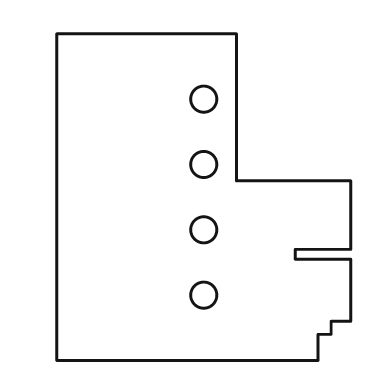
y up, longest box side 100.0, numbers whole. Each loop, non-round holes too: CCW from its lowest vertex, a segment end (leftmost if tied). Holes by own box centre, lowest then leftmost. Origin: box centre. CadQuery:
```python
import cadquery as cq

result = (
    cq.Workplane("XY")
    .moveTo(-45.0, -50.0)
    .lineTo(35.0, -50.0)
    .lineTo(35.0, -42.0)
    .lineTo(39.0, -42.0)
    .lineTo(39.0, -38.0)
    .lineTo(45.0, -38.0)
    .lineTo(45.0, -19.0)
    .lineTo(28.0, -19.0)
    .lineTo(28.0, -16.0)
    .lineTo(45.0, -16.0)
    .lineTo(45.0, 5.0)
    .lineTo(10.0, 5.0)
    .lineTo(10.0, 50.0)
    .lineTo(-45.0, 50.0)
    .close()
    .moveTo(0.0, -30.0)
    .circle(4.0)
    .moveTo(0.0, -10.0)
    .circle(4.0)
    .moveTo(0.0, 10.0)
    .circle(4.0)
    .moveTo(0.0, 30.0)
    .circle(4.0)
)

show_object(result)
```